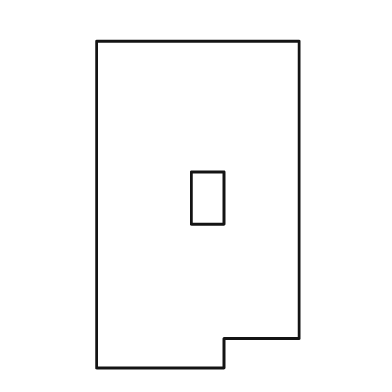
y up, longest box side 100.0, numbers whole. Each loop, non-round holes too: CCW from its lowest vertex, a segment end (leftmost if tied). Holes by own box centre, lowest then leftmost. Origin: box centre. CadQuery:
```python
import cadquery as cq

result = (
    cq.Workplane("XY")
    .moveTo(-31.0, -50.0)
    .lineTo(8.0, -50.0)
    .lineTo(8.0, -41.0)
    .lineTo(31.0, -41.0)
    .lineTo(31.0, 50.0)
    .lineTo(-31.0, 50.0)
    .close()
    .moveTo(-2.0, -6.0)
    .lineTo(8.0, -6.0)
    .lineTo(8.0, 10.0)
    .lineTo(-2.0, 10.0)
    .close()
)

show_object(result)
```